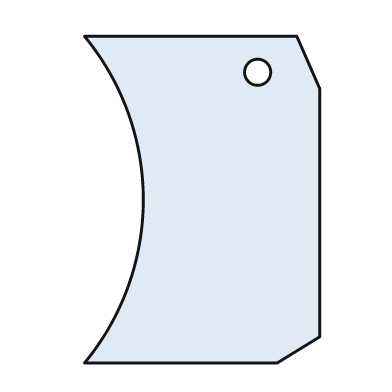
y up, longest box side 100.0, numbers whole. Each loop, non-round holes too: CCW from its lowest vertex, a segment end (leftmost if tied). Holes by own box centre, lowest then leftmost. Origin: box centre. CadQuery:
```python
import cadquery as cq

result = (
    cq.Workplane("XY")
    .moveTo(-36.0, -50.0)
    .lineTo(23.0, -50.0)
    .lineTo(36.0, -42.0)
    .lineTo(36.0, 34.0)
    .lineTo(29.0, 50.0)
    .lineTo(-36.0, 50.0)
    .threePointArc((-18.0, 0.0), (-36.0, -50.0))
    .close()
    .moveTo(17.0, 39.0)
    .circle(4.0)
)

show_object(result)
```